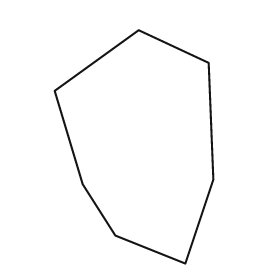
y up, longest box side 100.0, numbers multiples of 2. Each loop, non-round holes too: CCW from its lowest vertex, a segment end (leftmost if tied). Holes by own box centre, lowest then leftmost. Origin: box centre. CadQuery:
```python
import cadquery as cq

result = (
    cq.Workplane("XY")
    .moveTo(22.0, -50.0)
    .lineTo(34.0, -14.0)
    .lineTo(32.0, 36.0)
    .lineTo(2.0, 50.0)
    .lineTo(-34.0, 24.0)
    .lineTo(-22.0, -16.0)
    .lineTo(-8.0, -38.0)
    .close()
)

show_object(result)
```